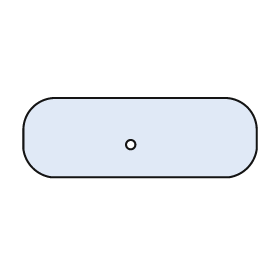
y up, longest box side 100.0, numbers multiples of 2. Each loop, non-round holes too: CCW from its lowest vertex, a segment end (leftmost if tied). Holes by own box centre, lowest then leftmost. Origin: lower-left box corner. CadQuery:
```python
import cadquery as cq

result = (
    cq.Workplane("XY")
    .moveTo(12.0, 0.0)
    .lineTo(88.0, 0.0)
    .threePointArc((96.0, 4.0), (100.0, 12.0))
    .lineTo(100.0, 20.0)
    .threePointArc((96.0, 30.0), (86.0, 34.0))
    .lineTo(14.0, 34.0)
    .threePointArc((4.0, 30.0), (0.0, 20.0))
    .lineTo(0.0, 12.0)
    .threePointArc((4.0, 4.0), (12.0, 0.0))
    .close()
    .moveTo(46.0, 14.0)
    .circle(2.0)
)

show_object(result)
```